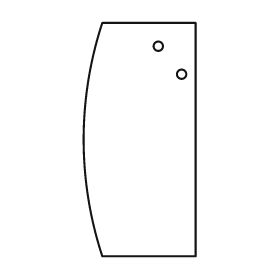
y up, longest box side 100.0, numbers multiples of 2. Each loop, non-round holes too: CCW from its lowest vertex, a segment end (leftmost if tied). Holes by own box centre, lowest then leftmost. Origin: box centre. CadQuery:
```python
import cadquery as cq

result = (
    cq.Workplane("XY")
    .moveTo(-16.0, -50.0)
    .lineTo(24.0, -50.0)
    .lineTo(24.0, 50.0)
    .lineTo(-16.0, 50.0)
    .threePointArc((-24.0, 0.0), (-16.0, -50.0))
    .close()
    .moveTo(18.0, 28.0)
    .circle(2.0)
    .moveTo(8.0, 40.0)
    .circle(2.0)
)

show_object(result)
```